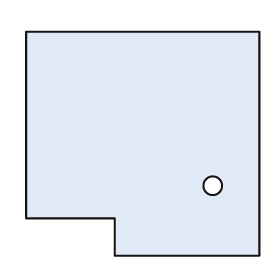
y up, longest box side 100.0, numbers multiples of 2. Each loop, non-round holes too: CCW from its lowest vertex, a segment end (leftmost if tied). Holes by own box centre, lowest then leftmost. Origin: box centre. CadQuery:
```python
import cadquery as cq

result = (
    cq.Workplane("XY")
    .moveTo(-12.0, -48.0)
    .lineTo(50.0, -48.0)
    .lineTo(50.0, 48.0)
    .lineTo(-50.0, 48.0)
    .lineTo(-50.0, -32.0)
    .lineTo(-12.0, -32.0)
    .close()
    .moveTo(30.0, -18.0)
    .circle(4.0)
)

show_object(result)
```